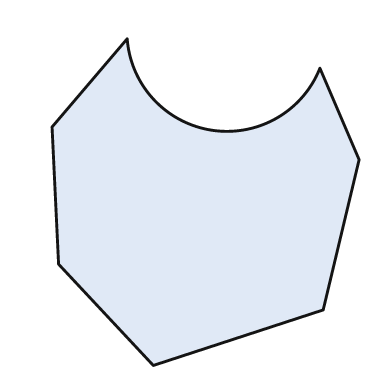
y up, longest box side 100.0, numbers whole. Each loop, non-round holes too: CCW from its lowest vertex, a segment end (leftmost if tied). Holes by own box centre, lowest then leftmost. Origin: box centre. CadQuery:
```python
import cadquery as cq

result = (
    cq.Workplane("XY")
    .moveTo(-16.0, -50.0)
    .lineTo(36.0, -33.0)
    .lineTo(47.0, 13.0)
    .lineTo(35.0, 41.0)
    .threePointArc((2.0, 22.0), (-24.0, 50.0))
    .lineTo(-47.0, 23.0)
    .lineTo(-45.0, -19.0)
    .close()
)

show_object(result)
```